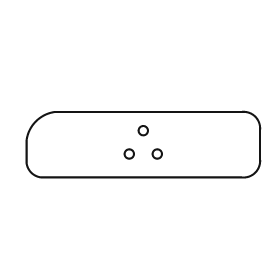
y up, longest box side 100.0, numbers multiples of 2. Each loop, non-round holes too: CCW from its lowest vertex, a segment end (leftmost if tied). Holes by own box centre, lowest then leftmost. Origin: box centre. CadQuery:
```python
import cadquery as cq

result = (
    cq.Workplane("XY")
    .moveTo(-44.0, -14.0)
    .lineTo(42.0, -14.0)
    .threePointArc((48.0, -12.0), (50.0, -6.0))
    .lineTo(50.0, 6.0)
    .threePointArc((48.0, 12.0), (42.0, 14.0))
    .lineTo(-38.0, 14.0)
    .threePointArc((-46.0, 10.0), (-50.0, 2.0))
    .lineTo(-50.0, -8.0)
    .threePointArc((-48.0, -12.0), (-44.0, -14.0))
    .close()
    .moveTo(-6.0, -4.0)
    .circle(2.0)
    .moveTo(6.0, -4.0)
    .circle(2.0)
    .moveTo(0.0, 6.0)
    .circle(2.0)
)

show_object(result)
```